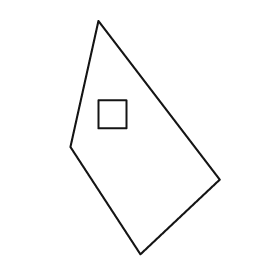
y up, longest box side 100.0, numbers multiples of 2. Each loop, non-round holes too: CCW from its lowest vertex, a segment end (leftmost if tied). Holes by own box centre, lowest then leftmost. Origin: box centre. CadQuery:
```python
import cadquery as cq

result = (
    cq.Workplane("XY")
    .moveTo(-2.0, -50.0)
    .lineTo(32.0, -18.0)
    .lineTo(-20.0, 50.0)
    .lineTo(-32.0, -4.0)
    .close()
    .moveTo(-20.0, 4.0)
    .lineTo(-8.0, 4.0)
    .lineTo(-8.0, 16.0)
    .lineTo(-20.0, 16.0)
    .close()
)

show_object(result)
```